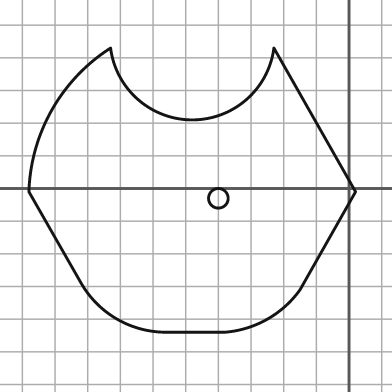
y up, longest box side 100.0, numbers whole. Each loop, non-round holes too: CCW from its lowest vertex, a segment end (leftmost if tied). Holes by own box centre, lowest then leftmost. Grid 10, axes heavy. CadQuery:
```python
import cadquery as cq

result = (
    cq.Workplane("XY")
    .moveTo(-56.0, -44.0)
    .lineTo(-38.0, -44.0)
    .threePointArc((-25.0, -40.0), (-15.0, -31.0))
    .lineTo(2.0, -1.0)
    .lineTo(-23.0, 43.0)
    .threePointArc((-48.0, 21.0), (-73.0, 43.0))
    .threePointArc((-91.0, 24.0), (-98.0, -1.0))
    .lineTo(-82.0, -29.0)
    .threePointArc((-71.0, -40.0), (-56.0, -44.0))
    .close()
    .moveTo(-40.0, -3.0)
    .circle(3.0)
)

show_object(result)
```